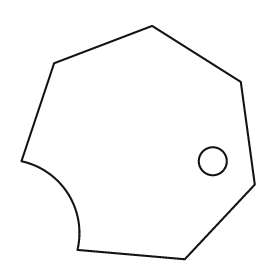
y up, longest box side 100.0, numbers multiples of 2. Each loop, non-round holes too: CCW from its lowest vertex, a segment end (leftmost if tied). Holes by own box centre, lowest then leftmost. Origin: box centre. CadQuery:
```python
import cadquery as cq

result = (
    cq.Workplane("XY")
    .moveTo(20.0, -50.0)
    .lineTo(50.0, -18.0)
    .lineTo(44.0, 26.0)
    .lineTo(6.0, 50.0)
    .lineTo(-36.0, 34.0)
    .lineTo(-50.0, -8.0)
    .threePointArc((-30.0, -22.0), (-26.0, -46.0))
    .close()
    .moveTo(32.0, -8.0)
    .circle(6.0)
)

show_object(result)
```